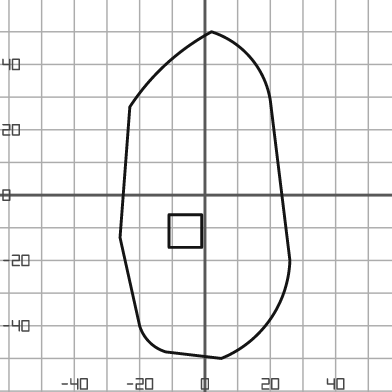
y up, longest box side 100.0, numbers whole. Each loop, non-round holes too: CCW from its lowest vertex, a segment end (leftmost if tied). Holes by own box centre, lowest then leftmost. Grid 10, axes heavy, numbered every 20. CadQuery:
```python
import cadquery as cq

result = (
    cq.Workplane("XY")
    .moveTo(5.0, -50.0)
    .threePointArc((20.0, -38.0), (26.0, -20.0))
    .lineTo(20.0, 29.0)
    .threePointArc((14.0, 42.0), (2.0, 50.0))
    .threePointArc((-12.0, 40.0), (-23.0, 27.0))
    .lineTo(-26.0, -13.0)
    .lineTo(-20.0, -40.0)
    .threePointArc((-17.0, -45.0), (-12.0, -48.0))
    .close()
    .moveTo(-11.0, -16.0)
    .lineTo(-1.0, -16.0)
    .lineTo(-1.0, -6.0)
    .lineTo(-11.0, -6.0)
    .close()
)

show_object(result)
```